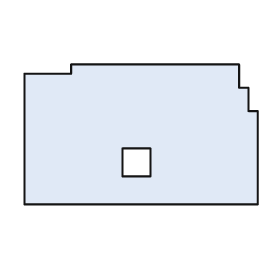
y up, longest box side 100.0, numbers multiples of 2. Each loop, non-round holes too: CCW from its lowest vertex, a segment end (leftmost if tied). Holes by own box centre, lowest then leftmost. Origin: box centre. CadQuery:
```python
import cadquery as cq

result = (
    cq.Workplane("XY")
    .moveTo(-50.0, -30.0)
    .lineTo(50.0, -30.0)
    .lineTo(50.0, 10.0)
    .lineTo(46.0, 10.0)
    .lineTo(46.0, 20.0)
    .lineTo(42.0, 20.0)
    .lineTo(42.0, 30.0)
    .lineTo(-30.0, 30.0)
    .lineTo(-30.0, 26.0)
    .lineTo(-50.0, 26.0)
    .close()
    .moveTo(-8.0, -18.0)
    .lineTo(4.0, -18.0)
    .lineTo(4.0, -6.0)
    .lineTo(-8.0, -6.0)
    .close()
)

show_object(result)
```